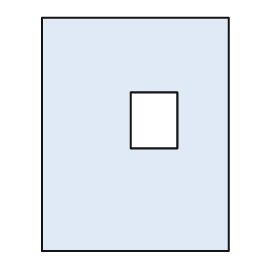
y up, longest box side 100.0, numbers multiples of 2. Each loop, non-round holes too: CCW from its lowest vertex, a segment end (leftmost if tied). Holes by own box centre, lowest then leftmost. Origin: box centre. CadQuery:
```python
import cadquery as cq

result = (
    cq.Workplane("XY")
    .moveTo(-40.0, -50.0)
    .lineTo(40.0, -50.0)
    .lineTo(40.0, 50.0)
    .lineTo(-40.0, 50.0)
    .close()
    .moveTo(-2.0, -6.0)
    .lineTo(18.0, -6.0)
    .lineTo(18.0, 18.0)
    .lineTo(-2.0, 18.0)
    .close()
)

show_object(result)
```